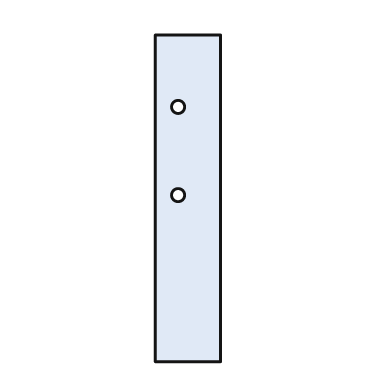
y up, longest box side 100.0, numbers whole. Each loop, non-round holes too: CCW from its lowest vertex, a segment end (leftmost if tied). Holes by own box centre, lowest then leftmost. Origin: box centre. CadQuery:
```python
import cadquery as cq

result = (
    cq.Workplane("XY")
    .moveTo(-10.0, -50.0)
    .lineTo(10.0, -50.0)
    .lineTo(10.0, 50.0)
    .lineTo(-10.0, 50.0)
    .close()
    .moveTo(-3.0, 1.0)
    .circle(2.0)
    .moveTo(-3.0, 28.0)
    .circle(2.0)
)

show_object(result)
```